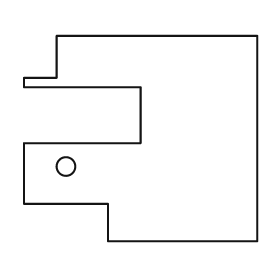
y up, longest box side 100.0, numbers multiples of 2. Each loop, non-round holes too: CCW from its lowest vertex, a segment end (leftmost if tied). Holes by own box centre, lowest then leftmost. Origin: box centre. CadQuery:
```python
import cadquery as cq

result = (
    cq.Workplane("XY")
    .moveTo(-14.0, -44.0)
    .lineTo(50.0, -44.0)
    .lineTo(50.0, 44.0)
    .lineTo(-36.0, 44.0)
    .lineTo(-36.0, 26.0)
    .lineTo(-50.0, 26.0)
    .lineTo(-50.0, 22.0)
    .lineTo(0.0, 22.0)
    .lineTo(0.0, -2.0)
    .lineTo(-50.0, -2.0)
    .lineTo(-50.0, -28.0)
    .lineTo(-14.0, -28.0)
    .close()
    .moveTo(-32.0, -12.0)
    .circle(4.0)
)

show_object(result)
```